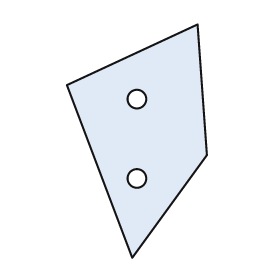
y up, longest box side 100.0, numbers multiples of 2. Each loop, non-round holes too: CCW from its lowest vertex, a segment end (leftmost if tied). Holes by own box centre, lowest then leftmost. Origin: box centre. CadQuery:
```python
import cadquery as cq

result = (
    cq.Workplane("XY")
    .moveTo(-2.0, -50.0)
    .lineTo(30.0, -6.0)
    .lineTo(26.0, 50.0)
    .lineTo(-30.0, 24.0)
    .close()
    .moveTo(0.0, -16.0)
    .circle(4.0)
    .moveTo(0.0, 18.0)
    .circle(4.0)
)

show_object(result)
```